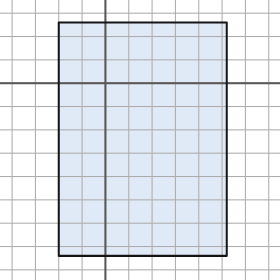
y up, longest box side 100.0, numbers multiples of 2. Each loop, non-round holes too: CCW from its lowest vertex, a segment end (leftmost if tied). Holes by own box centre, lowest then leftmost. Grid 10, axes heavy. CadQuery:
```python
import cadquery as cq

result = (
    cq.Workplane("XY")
    .moveTo(-20.0, -74.0)
    .lineTo(52.0, -74.0)
    .lineTo(52.0, 26.0)
    .lineTo(-20.0, 26.0)
    .close()
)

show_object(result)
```